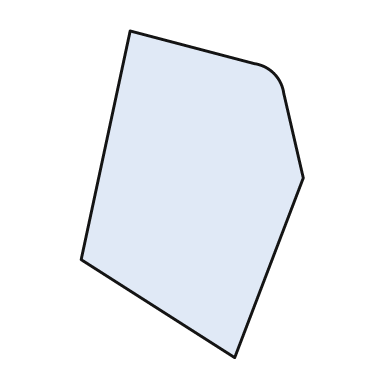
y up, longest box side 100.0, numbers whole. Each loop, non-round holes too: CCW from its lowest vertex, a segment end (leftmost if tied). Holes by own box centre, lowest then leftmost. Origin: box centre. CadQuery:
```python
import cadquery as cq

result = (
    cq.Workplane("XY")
    .moveTo(13.0, -50.0)
    .lineTo(34.0, 5.0)
    .lineTo(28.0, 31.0)
    .threePointArc((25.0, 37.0), (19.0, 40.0))
    .lineTo(-19.0, 50.0)
    .lineTo(-34.0, -20.0)
    .close()
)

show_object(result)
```